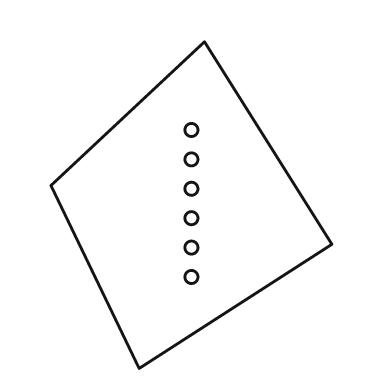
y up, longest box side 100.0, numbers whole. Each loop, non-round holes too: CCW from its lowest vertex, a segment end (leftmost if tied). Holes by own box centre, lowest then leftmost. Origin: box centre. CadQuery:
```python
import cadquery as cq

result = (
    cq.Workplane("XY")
    .moveTo(-16.0, -50.0)
    .lineTo(43.0, -12.0)
    .lineTo(4.0, 50.0)
    .lineTo(-43.0, 6.0)
    .close()
    .moveTo(0.0, -22.0)
    .circle(2.0)
    .moveTo(0.0, -13.0)
    .circle(2.0)
    .moveTo(0.0, -4.0)
    .circle(2.0)
    .moveTo(0.0, 5.0)
    .circle(2.0)
    .moveTo(0.0, 14.0)
    .circle(2.0)
    .moveTo(0.0, 23.0)
    .circle(2.0)
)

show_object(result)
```